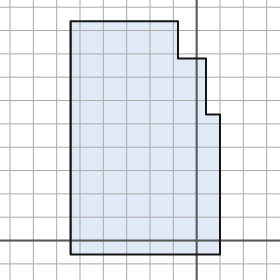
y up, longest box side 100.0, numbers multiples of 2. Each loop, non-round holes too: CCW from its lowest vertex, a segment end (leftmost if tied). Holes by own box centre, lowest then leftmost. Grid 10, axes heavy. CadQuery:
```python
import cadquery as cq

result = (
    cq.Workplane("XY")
    .moveTo(-54.0, -6.0)
    .lineTo(10.0, -6.0)
    .lineTo(10.0, 54.0)
    .lineTo(4.0, 54.0)
    .lineTo(4.0, 78.0)
    .lineTo(-8.0, 78.0)
    .lineTo(-8.0, 94.0)
    .lineTo(-54.0, 94.0)
    .close()
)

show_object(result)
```